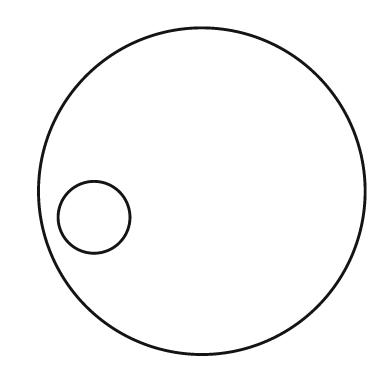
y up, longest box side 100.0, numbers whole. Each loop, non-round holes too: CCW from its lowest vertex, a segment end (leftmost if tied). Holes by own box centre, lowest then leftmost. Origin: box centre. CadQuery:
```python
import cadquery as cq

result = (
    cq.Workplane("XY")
    .moveTo(0.0, 0.0)
    .circle(50.0)
    .moveTo(-33.0, -8.0)
    .circle(11.0)
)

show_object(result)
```